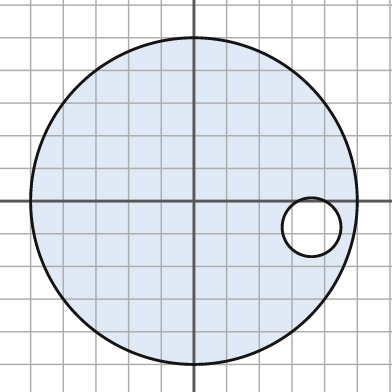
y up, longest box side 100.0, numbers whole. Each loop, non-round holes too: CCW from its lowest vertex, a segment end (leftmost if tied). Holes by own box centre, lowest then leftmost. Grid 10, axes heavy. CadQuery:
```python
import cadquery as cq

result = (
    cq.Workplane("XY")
    .moveTo(0.0, 0.0)
    .circle(50.0)
    .moveTo(36.0, -8.0)
    .circle(9.0)
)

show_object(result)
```